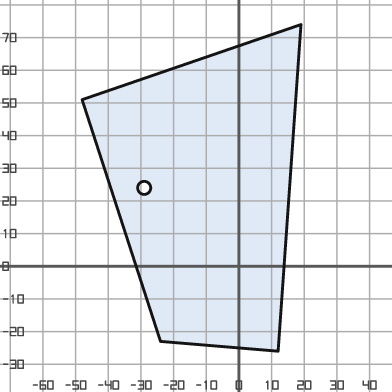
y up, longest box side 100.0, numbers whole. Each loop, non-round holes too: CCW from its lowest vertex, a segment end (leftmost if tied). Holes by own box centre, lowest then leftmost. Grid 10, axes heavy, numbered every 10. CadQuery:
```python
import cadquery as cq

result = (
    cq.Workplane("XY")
    .moveTo(12.0, -26.0)
    .lineTo(19.0, 74.0)
    .lineTo(-48.0, 51.0)
    .lineTo(-24.0, -23.0)
    .close()
    .moveTo(-29.0, 24.0)
    .circle(2.0)
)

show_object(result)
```